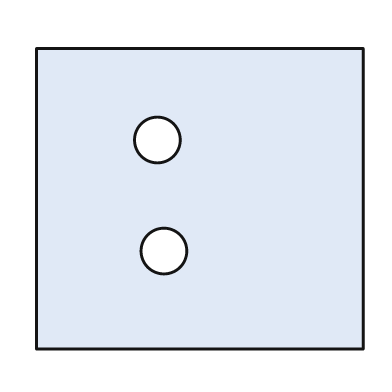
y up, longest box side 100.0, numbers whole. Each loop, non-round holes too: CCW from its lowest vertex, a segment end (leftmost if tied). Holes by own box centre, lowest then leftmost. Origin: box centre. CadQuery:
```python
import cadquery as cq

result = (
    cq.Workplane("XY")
    .moveTo(-50.0, -46.0)
    .lineTo(50.0, -46.0)
    .lineTo(50.0, 46.0)
    .lineTo(-50.0, 46.0)
    .close()
    .moveTo(-11.0, -16.0)
    .circle(7.0)
    .moveTo(-13.0, 18.0)
    .circle(7.0)
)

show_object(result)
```